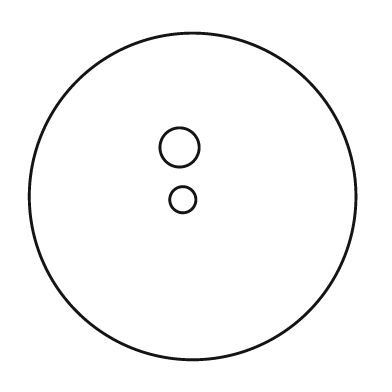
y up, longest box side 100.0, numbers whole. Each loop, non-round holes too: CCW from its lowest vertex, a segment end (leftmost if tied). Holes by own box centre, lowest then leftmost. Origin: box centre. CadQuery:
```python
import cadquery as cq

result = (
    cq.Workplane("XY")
    .moveTo(0.0, 0.0)
    .circle(50.0)
    .moveTo(-3.0, -1.0)
    .circle(4.0)
    .moveTo(-4.0, 15.0)
    .circle(6.0)
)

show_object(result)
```